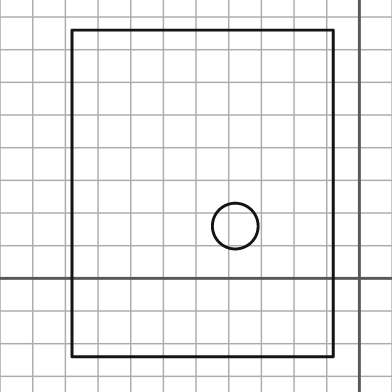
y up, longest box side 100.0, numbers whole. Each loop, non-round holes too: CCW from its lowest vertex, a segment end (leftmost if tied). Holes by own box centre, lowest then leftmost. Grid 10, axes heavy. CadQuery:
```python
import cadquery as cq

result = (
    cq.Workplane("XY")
    .moveTo(-88.0, -24.0)
    .lineTo(-8.0, -24.0)
    .lineTo(-8.0, 76.0)
    .lineTo(-88.0, 76.0)
    .close()
    .moveTo(-38.0, 16.0)
    .circle(7.0)
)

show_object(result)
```